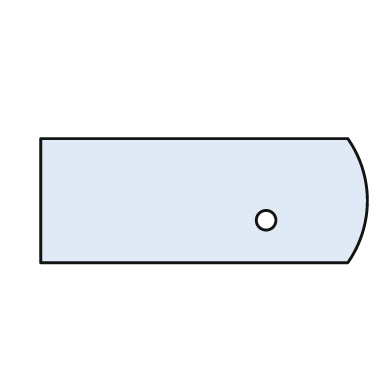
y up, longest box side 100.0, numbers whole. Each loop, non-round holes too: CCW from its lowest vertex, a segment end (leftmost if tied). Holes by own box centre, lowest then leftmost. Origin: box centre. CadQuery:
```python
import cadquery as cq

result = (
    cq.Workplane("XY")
    .moveTo(-50.0, -19.0)
    .lineTo(44.0, -19.0)
    .threePointArc((50.0, 0.0), (44.0, 19.0))
    .lineTo(-50.0, 19.0)
    .close()
    .moveTo(19.0, -6.0)
    .circle(3.0)
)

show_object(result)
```